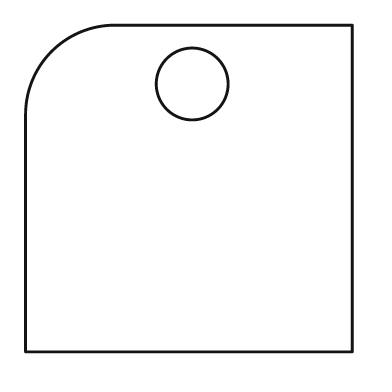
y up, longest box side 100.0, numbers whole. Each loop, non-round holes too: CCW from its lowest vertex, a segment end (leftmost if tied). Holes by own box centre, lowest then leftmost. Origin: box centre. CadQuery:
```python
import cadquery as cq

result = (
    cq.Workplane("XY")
    .moveTo(-50.0, -50.0)
    .lineTo(50.0, -50.0)
    .lineTo(50.0, 50.0)
    .lineTo(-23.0, 50.0)
    .threePointArc((-42.0, 42.0), (-50.0, 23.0))
    .close()
    .moveTo(1.0, 32.0)
    .circle(11.0)
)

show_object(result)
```